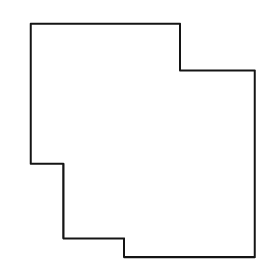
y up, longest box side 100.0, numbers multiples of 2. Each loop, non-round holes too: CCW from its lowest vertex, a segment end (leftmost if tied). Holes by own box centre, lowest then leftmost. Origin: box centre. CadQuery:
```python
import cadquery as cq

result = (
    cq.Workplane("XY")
    .moveTo(-8.0, -50.0)
    .lineTo(48.0, -50.0)
    .lineTo(48.0, 30.0)
    .lineTo(16.0, 30.0)
    .lineTo(16.0, 50.0)
    .lineTo(-48.0, 50.0)
    .lineTo(-48.0, -10.0)
    .lineTo(-34.0, -10.0)
    .lineTo(-34.0, -42.0)
    .lineTo(-8.0, -42.0)
    .close()
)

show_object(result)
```